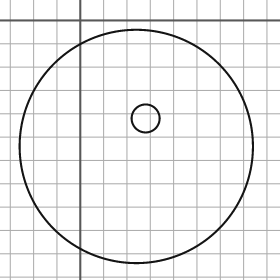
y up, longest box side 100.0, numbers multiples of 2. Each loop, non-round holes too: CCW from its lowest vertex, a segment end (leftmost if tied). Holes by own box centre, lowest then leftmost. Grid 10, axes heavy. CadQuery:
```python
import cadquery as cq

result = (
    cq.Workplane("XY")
    .moveTo(24.0, -54.0)
    .circle(50.0)
    .moveTo(28.0, -42.0)
    .circle(6.0)
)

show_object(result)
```